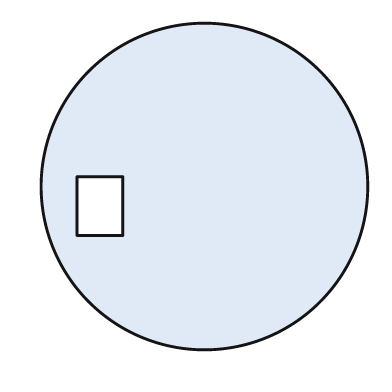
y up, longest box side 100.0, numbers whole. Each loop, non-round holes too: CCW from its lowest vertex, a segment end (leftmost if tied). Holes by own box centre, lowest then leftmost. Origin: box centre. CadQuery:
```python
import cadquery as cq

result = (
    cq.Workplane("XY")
    .moveTo(0.0, 0.0)
    .circle(50.0)
    .moveTo(-39.0, -15.0)
    .lineTo(-25.0, -15.0)
    .lineTo(-25.0, 3.0)
    .lineTo(-39.0, 3.0)
    .close()
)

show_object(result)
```